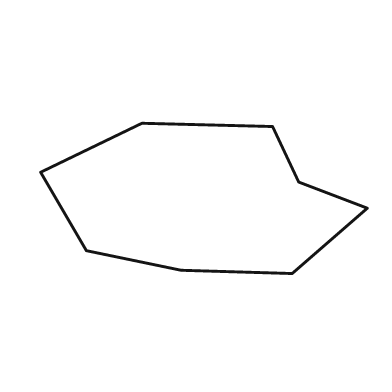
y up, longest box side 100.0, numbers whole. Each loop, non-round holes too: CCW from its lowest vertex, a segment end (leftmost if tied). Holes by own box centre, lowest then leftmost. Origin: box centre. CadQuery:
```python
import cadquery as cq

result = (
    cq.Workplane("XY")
    .moveTo(27.0, -23.0)
    .lineTo(50.0, -3.0)
    .lineTo(29.0, 5.0)
    .lineTo(21.0, 22.0)
    .lineTo(-19.0, 23.0)
    .lineTo(-50.0, 8.0)
    .lineTo(-36.0, -16.0)
    .lineTo(-7.0, -22.0)
    .close()
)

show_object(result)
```